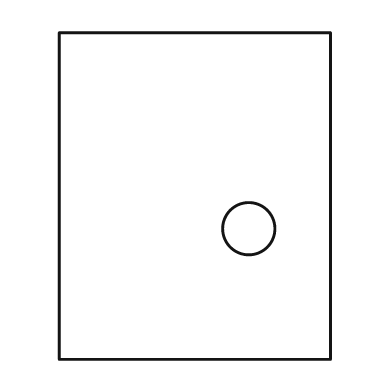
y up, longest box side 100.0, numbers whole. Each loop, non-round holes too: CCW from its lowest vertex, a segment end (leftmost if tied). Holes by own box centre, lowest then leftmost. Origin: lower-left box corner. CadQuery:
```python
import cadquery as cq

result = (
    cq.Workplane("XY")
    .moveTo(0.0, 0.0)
    .lineTo(83.0, 0.0)
    .lineTo(83.0, 100.0)
    .lineTo(0.0, 100.0)
    .close()
    .moveTo(58.0, 40.0)
    .circle(8.0)
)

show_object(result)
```